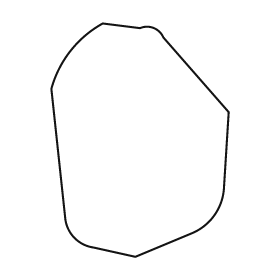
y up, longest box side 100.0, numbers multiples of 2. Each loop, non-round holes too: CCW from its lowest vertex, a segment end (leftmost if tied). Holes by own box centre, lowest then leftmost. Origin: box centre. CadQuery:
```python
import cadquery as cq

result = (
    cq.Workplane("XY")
    .moveTo(-2.0, -50.0)
    .lineTo(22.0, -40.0)
    .threePointArc((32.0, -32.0), (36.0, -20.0))
    .lineTo(38.0, 12.0)
    .lineTo(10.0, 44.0)
    .threePointArc((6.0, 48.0), (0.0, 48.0))
    .lineTo(-16.0, 50.0)
    .threePointArc((-30.0, 38.0), (-38.0, 22.0))
    .lineTo(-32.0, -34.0)
    .threePointArc((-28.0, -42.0), (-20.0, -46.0))
    .close()
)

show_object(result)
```